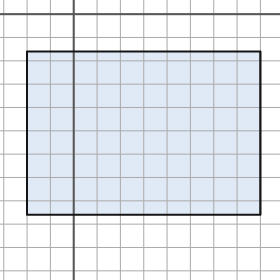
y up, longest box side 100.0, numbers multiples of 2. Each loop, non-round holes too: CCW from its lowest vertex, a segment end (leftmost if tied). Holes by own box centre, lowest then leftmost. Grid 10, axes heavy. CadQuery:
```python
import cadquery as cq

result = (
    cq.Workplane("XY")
    .moveTo(-20.0, -86.0)
    .lineTo(80.0, -86.0)
    .lineTo(80.0, -16.0)
    .lineTo(-20.0, -16.0)
    .close()
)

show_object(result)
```